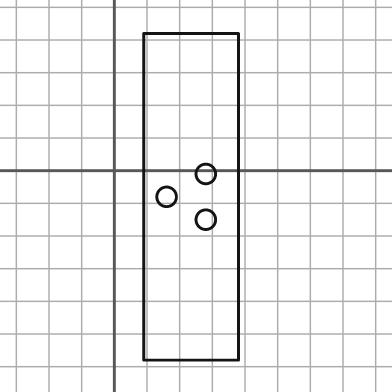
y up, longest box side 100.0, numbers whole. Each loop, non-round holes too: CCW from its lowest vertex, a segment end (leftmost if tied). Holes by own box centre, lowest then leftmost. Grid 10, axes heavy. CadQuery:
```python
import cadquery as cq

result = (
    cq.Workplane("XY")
    .moveTo(9.0, -58.0)
    .lineTo(38.0, -58.0)
    .lineTo(38.0, 42.0)
    .lineTo(9.0, 42.0)
    .close()
    .moveTo(28.0, -15.0)
    .circle(3.0)
    .moveTo(16.0, -8.0)
    .circle(3.0)
    .moveTo(28.0, -1.0)
    .circle(3.0)
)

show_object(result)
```